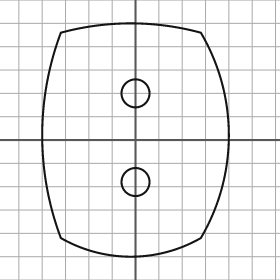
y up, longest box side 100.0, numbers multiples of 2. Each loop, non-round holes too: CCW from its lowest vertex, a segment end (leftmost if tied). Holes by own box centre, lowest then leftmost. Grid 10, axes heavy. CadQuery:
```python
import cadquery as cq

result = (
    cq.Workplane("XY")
    .moveTo(-32.0, -42.0)
    .threePointArc((-2.0, -50.0), (28.0, -42.0))
    .threePointArc((40.0, 2.0), (28.0, 46.0))
    .threePointArc((-2.0, 50.0), (-32.0, 46.0))
    .threePointArc((-40.0, 2.0), (-32.0, -42.0))
    .close()
    .moveTo(0.0, -18.0)
    .circle(6.0)
    .moveTo(0.0, 20.0)
    .circle(6.0)
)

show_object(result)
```